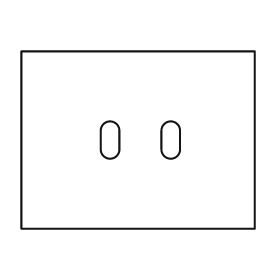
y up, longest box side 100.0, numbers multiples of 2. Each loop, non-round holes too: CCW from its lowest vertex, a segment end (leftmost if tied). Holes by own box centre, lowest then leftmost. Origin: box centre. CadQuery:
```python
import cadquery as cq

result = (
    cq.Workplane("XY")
    .moveTo(-50.0, -38.0)
    .lineTo(50.0, -38.0)
    .lineTo(50.0, 38.0)
    .lineTo(-50.0, 38.0)
    .close()
    .moveTo(-16.0, -4.0)
    .threePointArc((-12.0, -8.0), (-8.0, -4.0))
    .lineTo(-8.0, 4.0)
    .threePointArc((-12.0, 8.0), (-16.0, 4.0))
    .close()
    .moveTo(10.0, -4.0)
    .threePointArc((14.0, -8.0), (18.0, -4.0))
    .lineTo(18.0, 4.0)
    .threePointArc((14.0, 8.0), (10.0, 4.0))
    .close()
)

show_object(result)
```